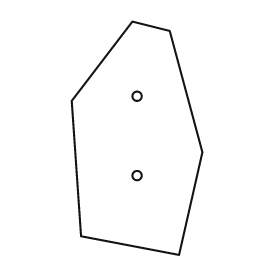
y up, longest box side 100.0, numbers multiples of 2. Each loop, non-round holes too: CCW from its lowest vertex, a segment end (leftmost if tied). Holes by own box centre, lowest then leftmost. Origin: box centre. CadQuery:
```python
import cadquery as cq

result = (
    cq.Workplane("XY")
    .moveTo(18.0, -50.0)
    .lineTo(28.0, -6.0)
    .lineTo(14.0, 46.0)
    .lineTo(-2.0, 50.0)
    .lineTo(-28.0, 16.0)
    .lineTo(-24.0, -42.0)
    .close()
    .moveTo(0.0, -16.0)
    .circle(2.0)
    .moveTo(0.0, 18.0)
    .circle(2.0)
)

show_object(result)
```